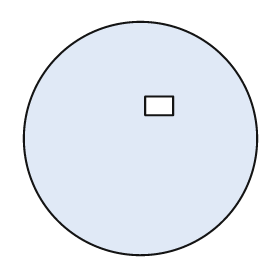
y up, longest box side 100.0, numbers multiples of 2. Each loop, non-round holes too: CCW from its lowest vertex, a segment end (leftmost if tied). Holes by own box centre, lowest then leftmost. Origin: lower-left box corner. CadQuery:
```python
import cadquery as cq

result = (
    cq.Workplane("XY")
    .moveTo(50.0, 50.0)
    .circle(50.0)
    .moveTo(52.0, 60.0)
    .lineTo(64.0, 60.0)
    .lineTo(64.0, 68.0)
    .lineTo(52.0, 68.0)
    .close()
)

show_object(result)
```